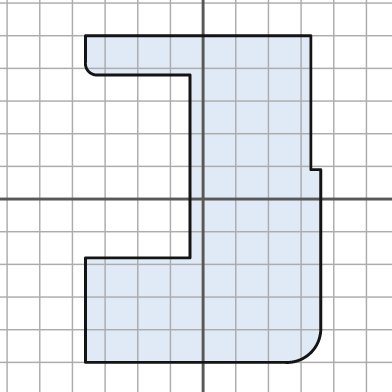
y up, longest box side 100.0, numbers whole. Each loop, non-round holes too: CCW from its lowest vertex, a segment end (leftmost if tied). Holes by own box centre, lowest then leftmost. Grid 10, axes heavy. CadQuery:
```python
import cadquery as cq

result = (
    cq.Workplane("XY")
    .moveTo(-36.0, -50.0)
    .lineTo(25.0, -50.0)
    .threePointArc((33.0, -47.0), (36.0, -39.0))
    .lineTo(36.0, 9.0)
    .lineTo(33.0, 9.0)
    .lineTo(33.0, 50.0)
    .lineTo(-36.0, 50.0)
    .lineTo(-36.0, 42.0)
    .threePointArc((-35.0, 39.0), (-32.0, 38.0))
    .lineTo(-4.0, 38.0)
    .lineTo(-4.0, -18.0)
    .lineTo(-36.0, -18.0)
    .close()
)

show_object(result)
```